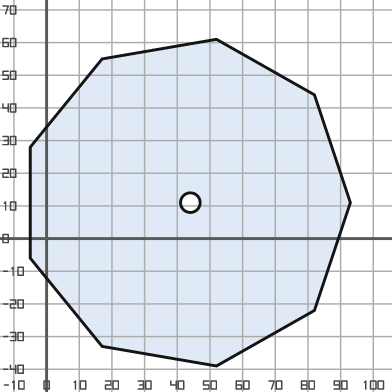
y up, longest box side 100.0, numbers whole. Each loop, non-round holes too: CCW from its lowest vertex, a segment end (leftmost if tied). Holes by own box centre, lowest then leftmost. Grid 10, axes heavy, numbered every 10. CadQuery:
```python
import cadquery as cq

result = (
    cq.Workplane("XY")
    .moveTo(52.0, -39.0)
    .lineTo(82.0, -22.0)
    .lineTo(93.0, 11.0)
    .lineTo(82.0, 44.0)
    .lineTo(52.0, 61.0)
    .lineTo(17.0, 55.0)
    .lineTo(-5.0, 28.0)
    .lineTo(-5.0, -6.0)
    .lineTo(17.0, -33.0)
    .close()
    .moveTo(44.0, 11.0)
    .circle(3.0)
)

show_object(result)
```